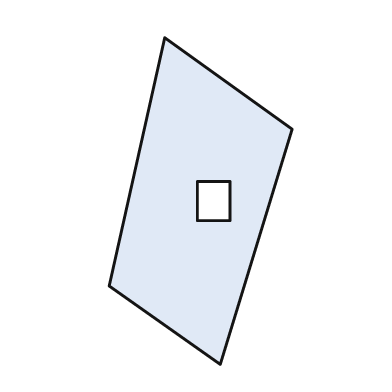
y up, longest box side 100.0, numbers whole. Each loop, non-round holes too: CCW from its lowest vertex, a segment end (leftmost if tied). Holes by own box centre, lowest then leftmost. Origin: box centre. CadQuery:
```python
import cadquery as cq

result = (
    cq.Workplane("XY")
    .moveTo(6.0, -50.0)
    .lineTo(28.0, 22.0)
    .lineTo(-11.0, 50.0)
    .lineTo(-28.0, -26.0)
    .close()
    .moveTo(-1.0, -6.0)
    .lineTo(9.0, -6.0)
    .lineTo(9.0, 6.0)
    .lineTo(-1.0, 6.0)
    .close()
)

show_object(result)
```